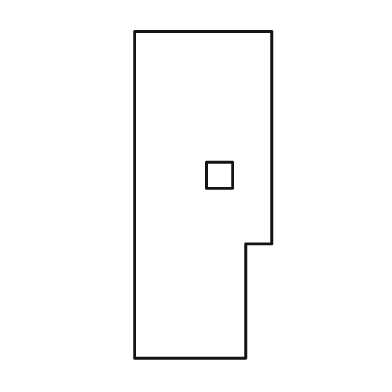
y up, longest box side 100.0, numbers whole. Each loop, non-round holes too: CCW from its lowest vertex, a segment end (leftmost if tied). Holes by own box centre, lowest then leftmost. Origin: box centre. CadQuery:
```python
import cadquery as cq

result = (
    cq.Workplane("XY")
    .moveTo(-21.0, -50.0)
    .lineTo(13.0, -50.0)
    .lineTo(13.0, -15.0)
    .lineTo(21.0, -15.0)
    .lineTo(21.0, 50.0)
    .lineTo(-21.0, 50.0)
    .close()
    .moveTo(1.0, 2.0)
    .lineTo(9.0, 2.0)
    .lineTo(9.0, 10.0)
    .lineTo(1.0, 10.0)
    .close()
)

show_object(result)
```